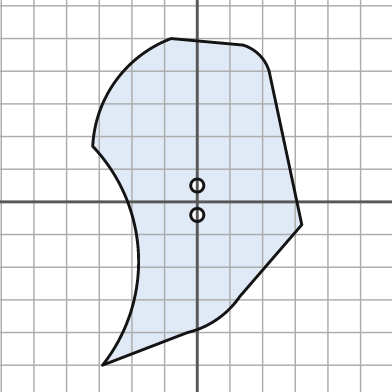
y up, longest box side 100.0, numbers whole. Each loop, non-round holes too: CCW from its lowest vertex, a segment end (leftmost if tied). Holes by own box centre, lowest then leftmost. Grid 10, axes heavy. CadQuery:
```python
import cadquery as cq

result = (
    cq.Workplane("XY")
    .moveTo(-29.0, -50.0)
    .lineTo(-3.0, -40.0)
    .threePointArc((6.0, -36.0), (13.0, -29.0))
    .lineTo(32.0, -7.0)
    .lineTo(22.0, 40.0)
    .threePointArc((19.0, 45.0), (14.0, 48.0))
    .lineTo(-8.0, 50.0)
    .threePointArc((-25.0, 37.0), (-32.0, 17.0))
    .threePointArc((-18.0, -16.0), (-29.0, -50.0))
    .close()
    .moveTo(0.0, -4.0)
    .circle(2.0)
    .moveTo(0.0, 5.0)
    .circle(2.0)
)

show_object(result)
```